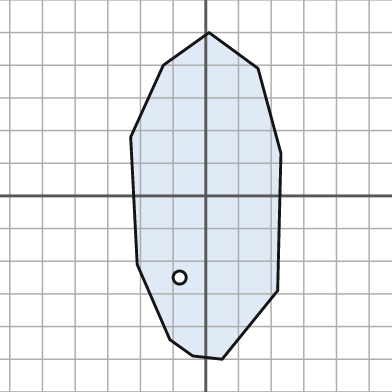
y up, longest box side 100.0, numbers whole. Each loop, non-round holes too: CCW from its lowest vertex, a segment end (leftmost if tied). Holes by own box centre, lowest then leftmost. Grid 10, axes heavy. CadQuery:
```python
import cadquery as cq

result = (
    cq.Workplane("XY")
    .moveTo(5.0, -50.0)
    .lineTo(22.0, -29.0)
    .lineTo(23.0, 13.0)
    .lineTo(16.0, 39.0)
    .lineTo(1.0, 50.0)
    .lineTo(-13.0, 40.0)
    .lineTo(-23.0, 18.0)
    .lineTo(-21.0, -21.0)
    .lineTo(-11.0, -44.0)
    .lineTo(-4.0, -49.0)
    .close()
    .moveTo(-8.0, -25.0)
    .circle(2.0)
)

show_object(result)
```